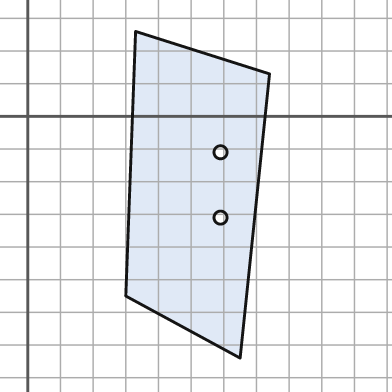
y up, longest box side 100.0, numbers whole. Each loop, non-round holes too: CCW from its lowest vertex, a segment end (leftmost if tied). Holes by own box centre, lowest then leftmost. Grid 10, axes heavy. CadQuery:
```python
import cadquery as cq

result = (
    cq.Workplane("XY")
    .moveTo(65.0, -74.0)
    .lineTo(74.0, 13.0)
    .lineTo(33.0, 26.0)
    .lineTo(30.0, -55.0)
    .close()
    .moveTo(59.0, -31.0)
    .circle(2.0)
    .moveTo(59.0, -11.0)
    .circle(2.0)
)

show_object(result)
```